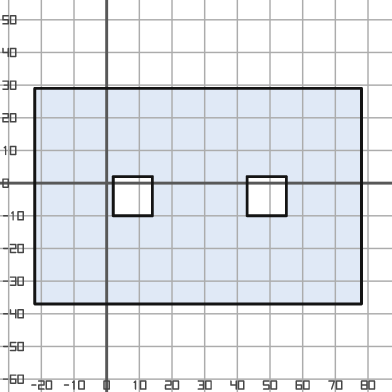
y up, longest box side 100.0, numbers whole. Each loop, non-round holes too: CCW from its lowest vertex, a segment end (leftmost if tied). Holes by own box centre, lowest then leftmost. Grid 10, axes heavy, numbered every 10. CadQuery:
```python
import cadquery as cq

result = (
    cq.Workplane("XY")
    .moveTo(-22.0, -37.0)
    .lineTo(78.0, -37.0)
    .lineTo(78.0, 29.0)
    .lineTo(-22.0, 29.0)
    .close()
    .moveTo(2.0, -10.0)
    .lineTo(14.0, -10.0)
    .lineTo(14.0, 2.0)
    .lineTo(2.0, 2.0)
    .close()
    .moveTo(43.0, -10.0)
    .lineTo(55.0, -10.0)
    .lineTo(55.0, 2.0)
    .lineTo(43.0, 2.0)
    .close()
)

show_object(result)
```